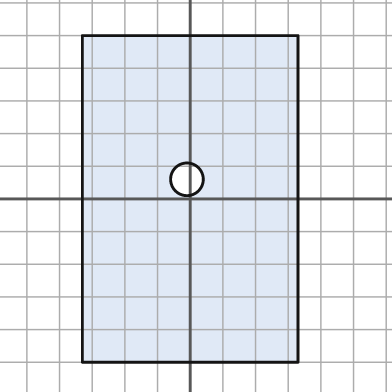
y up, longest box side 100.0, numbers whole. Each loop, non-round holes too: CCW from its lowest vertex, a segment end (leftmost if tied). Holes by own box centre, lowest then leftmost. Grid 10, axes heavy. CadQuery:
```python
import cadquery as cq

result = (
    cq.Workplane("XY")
    .moveTo(-33.0, -50.0)
    .lineTo(33.0, -50.0)
    .lineTo(33.0, 50.0)
    .lineTo(-33.0, 50.0)
    .close()
    .moveTo(-1.0, 6.0)
    .circle(5.0)
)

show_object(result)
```